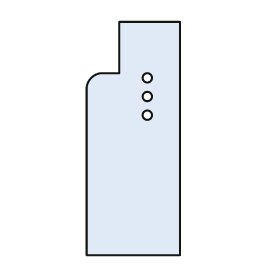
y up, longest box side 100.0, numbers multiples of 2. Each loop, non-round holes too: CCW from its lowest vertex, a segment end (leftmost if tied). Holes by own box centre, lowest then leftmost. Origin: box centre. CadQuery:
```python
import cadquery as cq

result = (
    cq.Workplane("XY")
    .moveTo(-20.0, -50.0)
    .lineTo(20.0, -50.0)
    .lineTo(20.0, 50.0)
    .lineTo(-6.0, 50.0)
    .lineTo(-6.0, 28.0)
    .lineTo(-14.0, 28.0)
    .threePointArc((-18.0, 26.0), (-20.0, 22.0))
    .close()
    .moveTo(6.0, 10.0)
    .circle(2.0)
    .moveTo(6.0, 18.0)
    .circle(2.0)
    .moveTo(6.0, 26.0)
    .circle(2.0)
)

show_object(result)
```